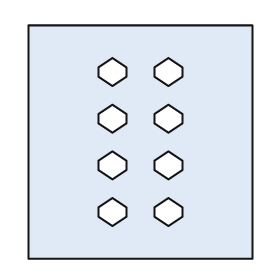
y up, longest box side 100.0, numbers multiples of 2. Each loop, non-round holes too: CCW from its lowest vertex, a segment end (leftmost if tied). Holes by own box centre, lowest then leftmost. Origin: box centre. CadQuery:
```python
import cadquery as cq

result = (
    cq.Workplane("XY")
    .moveTo(-48.0, -50.0)
    .lineTo(48.0, -50.0)
    .lineTo(48.0, 50.0)
    .lineTo(-48.0, 50.0)
    .close()
    .moveTo(-12.0, -36.0)
    .lineTo(-6.0, -32.0)
    .lineTo(-6.0, -28.0)
    .lineTo(-12.0, -24.0)
    .lineTo(-18.0, -28.0)
    .lineTo(-18.0, -32.0)
    .close()
    .moveTo(12.0, -36.0)
    .lineTo(18.0, -32.0)
    .lineTo(18.0, -28.0)
    .lineTo(12.0, -24.0)
    .lineTo(6.0, -28.0)
    .lineTo(6.0, -32.0)
    .close()
    .moveTo(-12.0, -16.0)
    .lineTo(-6.0, -12.0)
    .lineTo(-6.0, -8.0)
    .lineTo(-12.0, -4.0)
    .lineTo(-18.0, -8.0)
    .lineTo(-18.0, -12.0)
    .close()
    .moveTo(12.0, -16.0)
    .lineTo(18.0, -12.0)
    .lineTo(18.0, -8.0)
    .lineTo(12.0, -4.0)
    .lineTo(6.0, -8.0)
    .lineTo(6.0, -12.0)
    .close()
    .moveTo(-12.0, 4.0)
    .lineTo(-6.0, 8.0)
    .lineTo(-6.0, 12.0)
    .lineTo(-12.0, 16.0)
    .lineTo(-18.0, 12.0)
    .lineTo(-18.0, 8.0)
    .close()
    .moveTo(12.0, 4.0)
    .lineTo(18.0, 8.0)
    .lineTo(18.0, 12.0)
    .lineTo(12.0, 16.0)
    .lineTo(6.0, 12.0)
    .lineTo(6.0, 8.0)
    .close()
    .moveTo(-12.0, 24.0)
    .lineTo(-6.0, 28.0)
    .lineTo(-6.0, 32.0)
    .lineTo(-12.0, 36.0)
    .lineTo(-18.0, 32.0)
    .lineTo(-18.0, 28.0)
    .close()
    .moveTo(12.0, 24.0)
    .lineTo(18.0, 28.0)
    .lineTo(18.0, 32.0)
    .lineTo(12.0, 36.0)
    .lineTo(6.0, 32.0)
    .lineTo(6.0, 28.0)
    .close()
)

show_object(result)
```